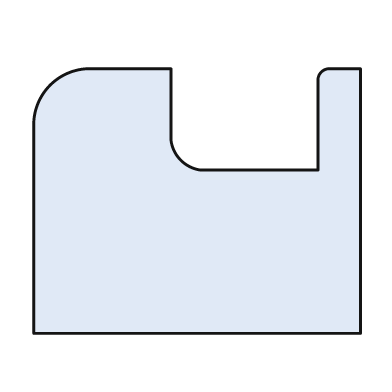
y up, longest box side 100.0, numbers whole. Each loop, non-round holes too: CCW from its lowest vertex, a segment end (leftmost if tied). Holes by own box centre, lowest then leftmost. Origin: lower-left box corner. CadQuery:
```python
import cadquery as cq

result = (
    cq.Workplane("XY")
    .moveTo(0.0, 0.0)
    .lineTo(100.0, 0.0)
    .lineTo(100.0, 81.0)
    .lineTo(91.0, 81.0)
    .threePointArc((88.0, 80.0), (87.0, 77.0))
    .lineTo(87.0, 50.0)
    .lineTo(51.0, 50.0)
    .threePointArc((45.0, 53.0), (42.0, 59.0))
    .lineTo(42.0, 81.0)
    .lineTo(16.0, 81.0)
    .threePointArc((5.0, 76.0), (0.0, 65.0))
    .close()
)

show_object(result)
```